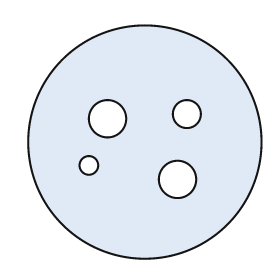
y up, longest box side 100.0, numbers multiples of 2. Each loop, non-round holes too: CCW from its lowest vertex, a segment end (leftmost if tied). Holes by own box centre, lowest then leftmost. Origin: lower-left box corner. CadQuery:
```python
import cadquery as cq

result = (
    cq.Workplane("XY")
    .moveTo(50.0, 50.0)
    .circle(50.0)
    .moveTo(64.0, 34.0)
    .circle(8.0)
    .moveTo(26.0, 40.0)
    .circle(4.0)
    .moveTo(34.0, 60.0)
    .circle(8.0)
    .moveTo(68.0, 62.0)
    .circle(6.0)
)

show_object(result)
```